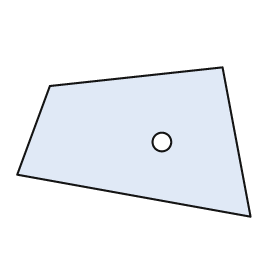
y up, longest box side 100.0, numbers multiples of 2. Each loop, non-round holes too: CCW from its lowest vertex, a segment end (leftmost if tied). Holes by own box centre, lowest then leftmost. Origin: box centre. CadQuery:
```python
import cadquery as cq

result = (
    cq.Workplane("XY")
    .moveTo(50.0, -32.0)
    .lineTo(38.0, 32.0)
    .lineTo(-36.0, 24.0)
    .lineTo(-50.0, -14.0)
    .close()
    .moveTo(12.0, 0.0)
    .circle(4.0)
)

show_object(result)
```